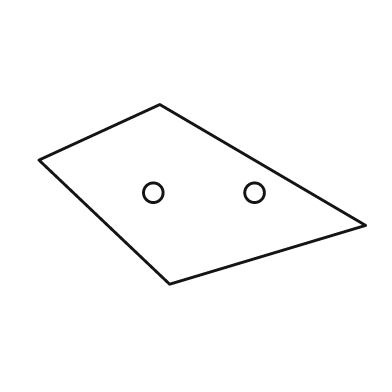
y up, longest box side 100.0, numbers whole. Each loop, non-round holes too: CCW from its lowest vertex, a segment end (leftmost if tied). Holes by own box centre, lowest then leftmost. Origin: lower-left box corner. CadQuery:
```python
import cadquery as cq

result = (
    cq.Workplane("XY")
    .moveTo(40.0, 0.0)
    .lineTo(100.0, 18.0)
    .lineTo(37.0, 55.0)
    .lineTo(0.0, 38.0)
    .close()
    .moveTo(35.0, 28.0)
    .circle(3.0)
    .moveTo(66.0, 28.0)
    .circle(3.0)
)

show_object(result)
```